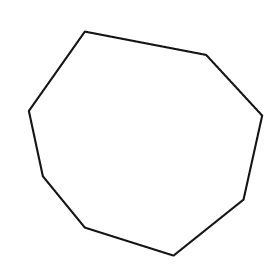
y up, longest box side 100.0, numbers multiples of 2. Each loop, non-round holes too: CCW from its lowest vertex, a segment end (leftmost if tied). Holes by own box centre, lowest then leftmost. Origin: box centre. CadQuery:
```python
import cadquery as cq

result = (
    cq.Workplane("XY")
    .moveTo(12.0, -48.0)
    .lineTo(42.0, -24.0)
    .lineTo(50.0, 12.0)
    .lineTo(26.0, 38.0)
    .lineTo(-26.0, 48.0)
    .lineTo(-50.0, 14.0)
    .lineTo(-44.0, -14.0)
    .lineTo(-26.0, -36.0)
    .close()
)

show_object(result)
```